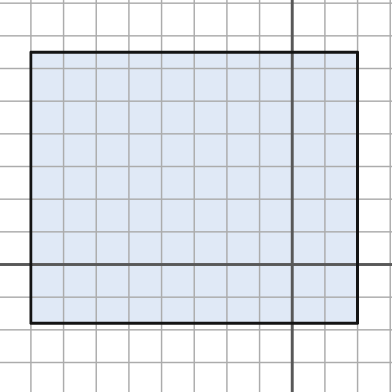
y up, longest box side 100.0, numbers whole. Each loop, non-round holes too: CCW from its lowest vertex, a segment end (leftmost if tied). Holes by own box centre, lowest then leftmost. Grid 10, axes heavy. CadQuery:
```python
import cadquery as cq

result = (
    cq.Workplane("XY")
    .moveTo(-80.0, -18.0)
    .lineTo(20.0, -18.0)
    .lineTo(20.0, 65.0)
    .lineTo(-80.0, 65.0)
    .close()
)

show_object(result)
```